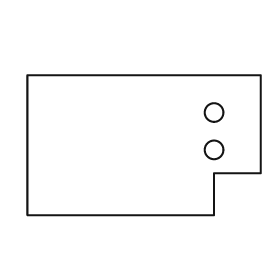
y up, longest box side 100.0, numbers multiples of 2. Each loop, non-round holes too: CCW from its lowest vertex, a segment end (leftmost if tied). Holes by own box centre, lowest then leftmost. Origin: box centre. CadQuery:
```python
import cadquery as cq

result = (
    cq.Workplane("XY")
    .moveTo(-50.0, -30.0)
    .lineTo(30.0, -30.0)
    .lineTo(30.0, -12.0)
    .lineTo(50.0, -12.0)
    .lineTo(50.0, 30.0)
    .lineTo(-50.0, 30.0)
    .close()
    .moveTo(30.0, -2.0)
    .circle(4.0)
    .moveTo(30.0, 14.0)
    .circle(4.0)
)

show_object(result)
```